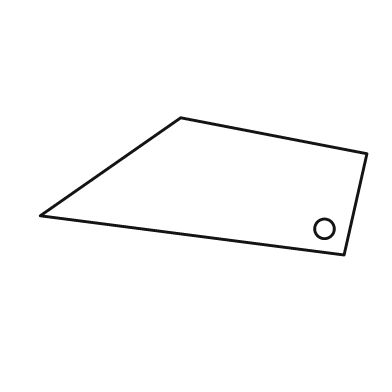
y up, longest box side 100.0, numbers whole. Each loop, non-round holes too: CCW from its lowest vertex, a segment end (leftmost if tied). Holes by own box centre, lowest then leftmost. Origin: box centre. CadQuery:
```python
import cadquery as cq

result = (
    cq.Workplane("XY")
    .moveTo(43.0, -21.0)
    .lineTo(50.0, 10.0)
    .lineTo(-7.0, 21.0)
    .lineTo(-50.0, -9.0)
    .close()
    .moveTo(37.0, -13.0)
    .circle(3.0)
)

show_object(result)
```